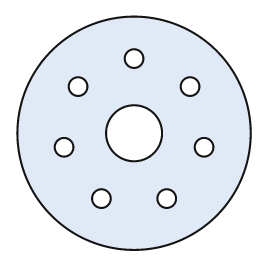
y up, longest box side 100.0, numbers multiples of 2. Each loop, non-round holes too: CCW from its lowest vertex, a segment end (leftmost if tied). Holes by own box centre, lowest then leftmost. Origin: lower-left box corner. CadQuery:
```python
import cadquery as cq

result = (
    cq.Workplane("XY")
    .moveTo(50.0, 50.0)
    .circle(50.0)
    .moveTo(36.0, 22.0)
    .circle(4.0)
    .moveTo(64.0, 22.0)
    .circle(4.0)
    .moveTo(20.0, 44.0)
    .circle(4.0)
    .moveTo(80.0, 44.0)
    .circle(4.0)
    .moveTo(50.0, 50.0)
    .circle(12.0)
    .moveTo(26.0, 70.0)
    .circle(4.0)
    .moveTo(74.0, 70.0)
    .circle(4.0)
    .moveTo(50.0, 82.0)
    .circle(4.0)
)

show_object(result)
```